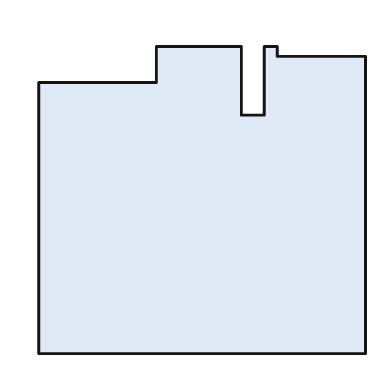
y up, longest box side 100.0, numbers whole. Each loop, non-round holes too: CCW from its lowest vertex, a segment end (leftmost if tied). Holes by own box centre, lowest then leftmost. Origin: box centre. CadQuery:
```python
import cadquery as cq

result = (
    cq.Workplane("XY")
    .moveTo(-50.0, -47.0)
    .lineTo(50.0, -47.0)
    .lineTo(50.0, 44.0)
    .lineTo(23.0, 44.0)
    .lineTo(23.0, 47.0)
    .lineTo(19.0, 47.0)
    .lineTo(19.0, 26.0)
    .lineTo(12.0, 26.0)
    .lineTo(12.0, 47.0)
    .lineTo(-14.0, 47.0)
    .lineTo(-14.0, 36.0)
    .lineTo(-50.0, 36.0)
    .close()
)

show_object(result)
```